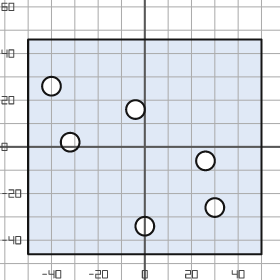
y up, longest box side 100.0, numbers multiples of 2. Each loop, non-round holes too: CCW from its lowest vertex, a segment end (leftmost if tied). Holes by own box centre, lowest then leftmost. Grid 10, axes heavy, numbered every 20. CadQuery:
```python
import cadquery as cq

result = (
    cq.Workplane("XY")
    .moveTo(-50.0, -46.0)
    .lineTo(50.0, -46.0)
    .lineTo(50.0, 46.0)
    .lineTo(-50.0, 46.0)
    .close()
    .moveTo(0.0, -34.0)
    .circle(4.0)
    .moveTo(30.0, -26.0)
    .circle(4.0)
    .moveTo(26.0, -6.0)
    .circle(4.0)
    .moveTo(-32.0, 2.0)
    .circle(4.0)
    .moveTo(-4.0, 16.0)
    .circle(4.0)
    .moveTo(-40.0, 26.0)
    .circle(4.0)
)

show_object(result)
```